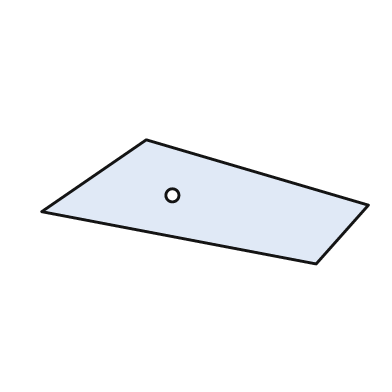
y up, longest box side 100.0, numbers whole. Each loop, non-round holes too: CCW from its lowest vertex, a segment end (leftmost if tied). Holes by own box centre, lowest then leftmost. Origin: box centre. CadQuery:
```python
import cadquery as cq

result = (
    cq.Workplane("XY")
    .moveTo(34.0, -19.0)
    .lineTo(50.0, -1.0)
    .lineTo(-18.0, 19.0)
    .lineTo(-50.0, -3.0)
    .close()
    .moveTo(-10.0, 2.0)
    .circle(2.0)
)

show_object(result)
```